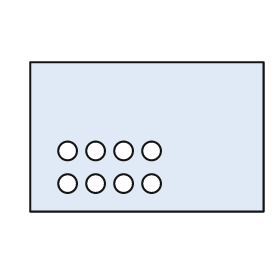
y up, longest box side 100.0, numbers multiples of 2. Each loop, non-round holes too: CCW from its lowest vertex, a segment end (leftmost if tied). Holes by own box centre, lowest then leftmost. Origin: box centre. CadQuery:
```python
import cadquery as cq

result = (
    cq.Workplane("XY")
    .moveTo(-50.0, -32.0)
    .lineTo(50.0, -32.0)
    .lineTo(50.0, 32.0)
    .lineTo(-50.0, 32.0)
    .close()
    .moveTo(-34.0, -20.0)
    .circle(4.0)
    .moveTo(-22.0, -20.0)
    .circle(4.0)
    .moveTo(-10.0, -20.0)
    .circle(4.0)
    .moveTo(2.0, -20.0)
    .circle(4.0)
    .moveTo(-34.0, -6.0)
    .circle(4.0)
    .moveTo(-22.0, -6.0)
    .circle(4.0)
    .moveTo(-10.0, -6.0)
    .circle(4.0)
    .moveTo(2.0, -6.0)
    .circle(4.0)
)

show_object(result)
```